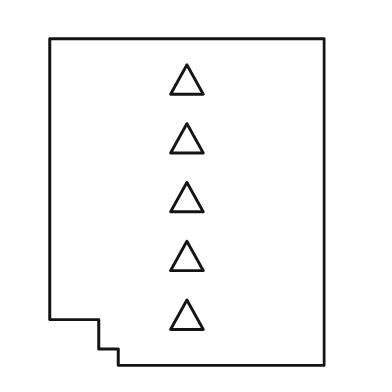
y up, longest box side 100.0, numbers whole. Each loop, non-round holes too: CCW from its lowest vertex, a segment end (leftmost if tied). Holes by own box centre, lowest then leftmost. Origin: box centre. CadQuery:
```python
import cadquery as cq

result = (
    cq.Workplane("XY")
    .moveTo(-21.0, -50.0)
    .lineTo(42.0, -50.0)
    .lineTo(42.0, 50.0)
    .lineTo(-42.0, 50.0)
    .lineTo(-42.0, -36.0)
    .lineTo(-27.0, -36.0)
    .lineTo(-27.0, -45.0)
    .lineTo(-21.0, -45.0)
    .close()
    .moveTo(-5.0, -39.0)
    .lineTo(5.0, -39.0)
    .lineTo(0.0, -30.0)
    .close()
    .moveTo(-5.0, -21.0)
    .lineTo(5.0, -21.0)
    .lineTo(0.0, -12.0)
    .close()
    .moveTo(-5.0, -3.0)
    .lineTo(5.0, -3.0)
    .lineTo(0.0, 6.0)
    .close()
    .moveTo(-5.0, 15.0)
    .lineTo(5.0, 15.0)
    .lineTo(0.0, 24.0)
    .close()
    .moveTo(-5.0, 33.0)
    .lineTo(5.0, 33.0)
    .lineTo(0.0, 42.0)
    .close()
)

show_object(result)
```